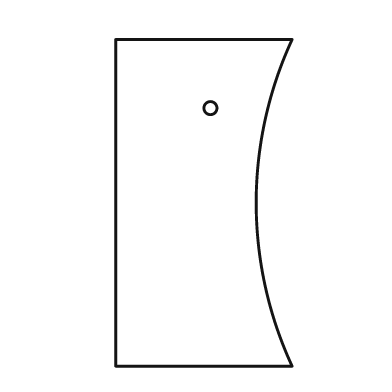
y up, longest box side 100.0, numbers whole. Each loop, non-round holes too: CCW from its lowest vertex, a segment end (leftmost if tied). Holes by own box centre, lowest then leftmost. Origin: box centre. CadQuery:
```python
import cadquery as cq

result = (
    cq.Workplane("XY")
    .moveTo(-27.0, -50.0)
    .lineTo(27.0, -50.0)
    .threePointArc((16.0, 0.0), (27.0, 50.0))
    .lineTo(-27.0, 50.0)
    .close()
    .moveTo(2.0, 29.0)
    .circle(2.0)
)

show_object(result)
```